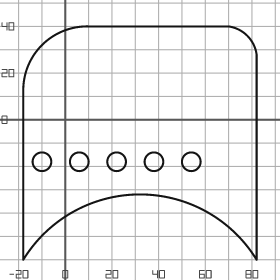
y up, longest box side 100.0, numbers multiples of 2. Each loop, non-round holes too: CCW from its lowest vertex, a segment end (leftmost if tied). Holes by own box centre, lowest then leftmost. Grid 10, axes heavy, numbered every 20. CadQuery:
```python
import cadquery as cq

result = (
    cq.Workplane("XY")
    .moveTo(-18.0, -60.0)
    .threePointArc((32.0, -32.0), (82.0, -60.0))
    .lineTo(82.0, 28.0)
    .threePointArc((78.0, 36.0), (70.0, 40.0))
    .lineTo(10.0, 40.0)
    .threePointArc((-10.0, 32.0), (-18.0, 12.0))
    .close()
    .moveTo(-10.0, -18.0)
    .circle(4.0)
    .moveTo(6.0, -18.0)
    .circle(4.0)
    .moveTo(22.0, -18.0)
    .circle(4.0)
    .moveTo(38.0, -18.0)
    .circle(4.0)
    .moveTo(54.0, -18.0)
    .circle(4.0)
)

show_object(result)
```